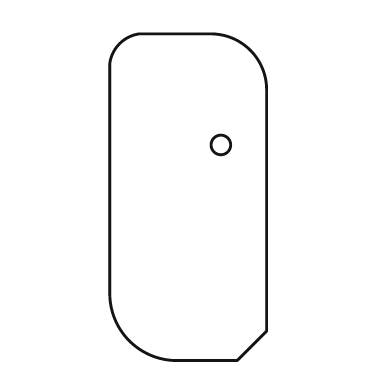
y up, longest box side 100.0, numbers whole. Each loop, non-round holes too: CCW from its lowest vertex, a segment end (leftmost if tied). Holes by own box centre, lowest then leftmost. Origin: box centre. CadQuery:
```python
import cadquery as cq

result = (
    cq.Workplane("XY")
    .moveTo(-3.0, -50.0)
    .lineTo(15.0, -50.0)
    .lineTo(24.0, -41.0)
    .lineTo(24.0, 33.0)
    .threePointArc((19.0, 45.0), (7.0, 50.0))
    .lineTo(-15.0, 50.0)
    .threePointArc((-21.0, 47.0), (-24.0, 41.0))
    .lineTo(-24.0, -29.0)
    .threePointArc((-18.0, -44.0), (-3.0, -50.0))
    .close()
    .moveTo(10.0, 16.0)
    .circle(3.0)
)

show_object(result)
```